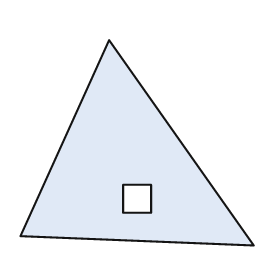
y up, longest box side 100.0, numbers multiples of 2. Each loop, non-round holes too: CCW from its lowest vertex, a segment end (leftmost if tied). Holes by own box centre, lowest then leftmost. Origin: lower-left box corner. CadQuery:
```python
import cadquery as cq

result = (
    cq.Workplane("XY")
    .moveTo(100.0, 0.0)
    .lineTo(38.0, 88.0)
    .lineTo(0.0, 4.0)
    .close()
    .moveTo(44.0, 14.0)
    .lineTo(56.0, 14.0)
    .lineTo(56.0, 26.0)
    .lineTo(44.0, 26.0)
    .close()
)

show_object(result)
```